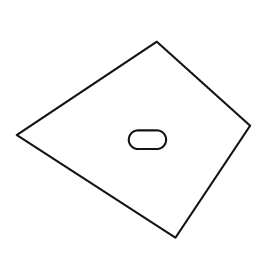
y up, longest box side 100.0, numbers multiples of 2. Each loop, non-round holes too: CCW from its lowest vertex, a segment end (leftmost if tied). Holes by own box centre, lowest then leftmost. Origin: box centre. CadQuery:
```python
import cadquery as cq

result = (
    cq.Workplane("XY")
    .moveTo(18.0, -42.0)
    .lineTo(50.0, 6.0)
    .lineTo(10.0, 42.0)
    .lineTo(-50.0, 2.0)
    .close()
    .moveTo(2.0, -4.0)
    .lineTo(10.0, -4.0)
    .threePointArc((14.0, 0.0), (10.0, 4.0))
    .lineTo(2.0, 4.0)
    .threePointArc((-2.0, 0.0), (2.0, -4.0))
    .close()
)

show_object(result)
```